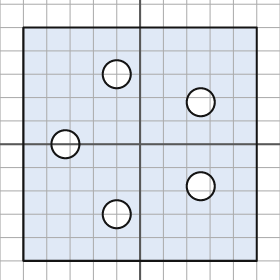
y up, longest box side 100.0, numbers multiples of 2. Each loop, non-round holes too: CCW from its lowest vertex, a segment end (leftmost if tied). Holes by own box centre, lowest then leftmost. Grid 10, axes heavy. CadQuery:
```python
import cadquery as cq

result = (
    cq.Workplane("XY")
    .moveTo(-50.0, -50.0)
    .lineTo(50.0, -50.0)
    .lineTo(50.0, 50.0)
    .lineTo(-50.0, 50.0)
    .close()
    .moveTo(-10.0, -30.0)
    .circle(6.0)
    .moveTo(26.0, -18.0)
    .circle(6.0)
    .moveTo(-32.0, 0.0)
    .circle(6.0)
    .moveTo(26.0, 18.0)
    .circle(6.0)
    .moveTo(-10.0, 30.0)
    .circle(6.0)
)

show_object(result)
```